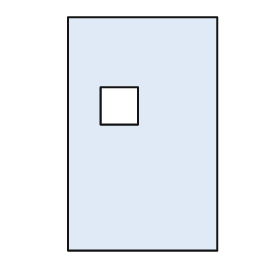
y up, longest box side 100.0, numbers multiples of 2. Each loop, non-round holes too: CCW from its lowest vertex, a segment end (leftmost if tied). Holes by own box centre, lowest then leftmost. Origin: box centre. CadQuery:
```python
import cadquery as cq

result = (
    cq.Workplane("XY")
    .moveTo(-32.0, -50.0)
    .lineTo(32.0, -50.0)
    .lineTo(32.0, 50.0)
    .lineTo(-32.0, 50.0)
    .close()
    .moveTo(-18.0, 4.0)
    .lineTo(-2.0, 4.0)
    .lineTo(-2.0, 20.0)
    .lineTo(-18.0, 20.0)
    .close()
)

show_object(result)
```